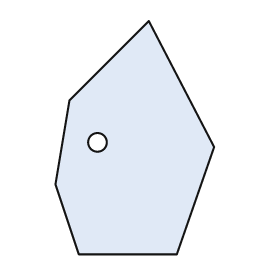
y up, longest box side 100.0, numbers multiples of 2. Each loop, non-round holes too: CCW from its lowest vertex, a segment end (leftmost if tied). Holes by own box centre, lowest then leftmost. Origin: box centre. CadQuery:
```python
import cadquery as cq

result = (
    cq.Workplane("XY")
    .moveTo(-24.0, -50.0)
    .lineTo(18.0, -50.0)
    .lineTo(34.0, -4.0)
    .lineTo(6.0, 50.0)
    .lineTo(-28.0, 16.0)
    .lineTo(-34.0, -20.0)
    .close()
    .moveTo(-16.0, -2.0)
    .circle(4.0)
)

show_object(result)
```